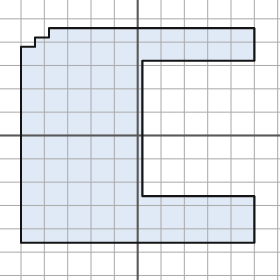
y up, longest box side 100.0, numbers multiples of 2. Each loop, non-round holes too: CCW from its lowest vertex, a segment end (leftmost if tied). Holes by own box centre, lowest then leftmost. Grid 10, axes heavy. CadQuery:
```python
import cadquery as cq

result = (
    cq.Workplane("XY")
    .moveTo(-50.0, -46.0)
    .lineTo(50.0, -46.0)
    .lineTo(50.0, -26.0)
    .lineTo(2.0, -26.0)
    .lineTo(2.0, 32.0)
    .lineTo(50.0, 32.0)
    .lineTo(50.0, 46.0)
    .lineTo(-38.0, 46.0)
    .lineTo(-38.0, 42.0)
    .lineTo(-44.0, 42.0)
    .lineTo(-44.0, 38.0)
    .lineTo(-50.0, 38.0)
    .close()
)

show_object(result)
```